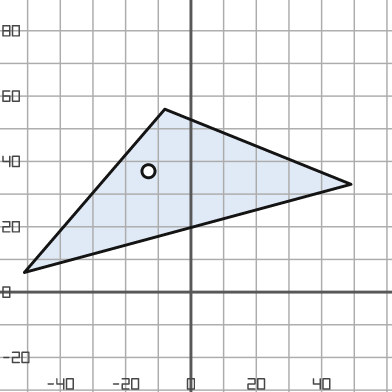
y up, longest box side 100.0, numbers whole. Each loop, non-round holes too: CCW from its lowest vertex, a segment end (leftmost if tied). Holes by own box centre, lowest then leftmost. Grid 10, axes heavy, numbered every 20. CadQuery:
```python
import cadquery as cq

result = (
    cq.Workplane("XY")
    .moveTo(-51.0, 6.0)
    .lineTo(49.0, 33.0)
    .lineTo(-8.0, 56.0)
    .close()
    .moveTo(-13.0, 37.0)
    .circle(2.0)
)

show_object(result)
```